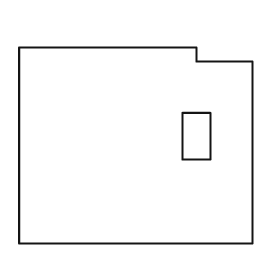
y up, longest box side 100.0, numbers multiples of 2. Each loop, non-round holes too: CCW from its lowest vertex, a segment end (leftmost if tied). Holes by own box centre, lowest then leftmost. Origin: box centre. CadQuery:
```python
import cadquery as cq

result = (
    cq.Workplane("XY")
    .moveTo(-50.0, -42.0)
    .lineTo(50.0, -42.0)
    .lineTo(50.0, 36.0)
    .lineTo(26.0, 36.0)
    .lineTo(26.0, 42.0)
    .lineTo(-50.0, 42.0)
    .close()
    .moveTo(20.0, -6.0)
    .lineTo(32.0, -6.0)
    .lineTo(32.0, 14.0)
    .lineTo(20.0, 14.0)
    .close()
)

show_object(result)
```